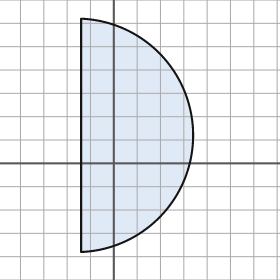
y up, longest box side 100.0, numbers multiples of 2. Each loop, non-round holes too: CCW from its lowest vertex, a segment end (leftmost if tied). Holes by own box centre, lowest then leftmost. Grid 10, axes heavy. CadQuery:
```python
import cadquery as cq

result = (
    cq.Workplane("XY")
    .moveTo(-14.0, -38.0)
    .threePointArc((34.0, 12.0), (-14.0, 62.0))
    .close()
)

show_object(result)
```